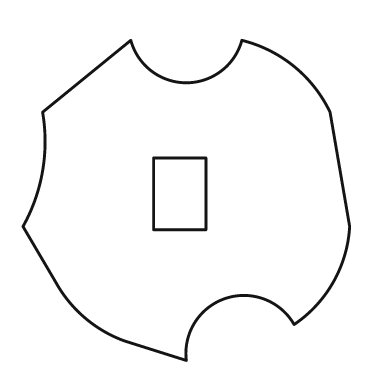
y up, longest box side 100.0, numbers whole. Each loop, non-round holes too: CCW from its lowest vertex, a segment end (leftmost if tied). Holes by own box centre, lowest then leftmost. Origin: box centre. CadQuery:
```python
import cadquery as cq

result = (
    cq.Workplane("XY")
    .moveTo(0.0, -49.0)
    .threePointArc((12.0, -30.0), (33.0, -38.0))
    .threePointArc((45.0, -25.0), (50.0, -8.0))
    .lineTo(44.0, 27.0)
    .threePointArc((33.0, 41.0), (17.0, 49.0))
    .threePointArc((0.0, 36.0), (-17.0, 49.0))
    .lineTo(-44.0, 27.0)
    .threePointArc((-44.0, 9.0), (-50.0, -8.0))
    .lineTo(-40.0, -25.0)
    .threePointArc((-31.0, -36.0), (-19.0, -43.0))
    .close()
    .moveTo(-10.0, -9.0)
    .lineTo(6.0, -9.0)
    .lineTo(6.0, 13.0)
    .lineTo(-10.0, 13.0)
    .close()
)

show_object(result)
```